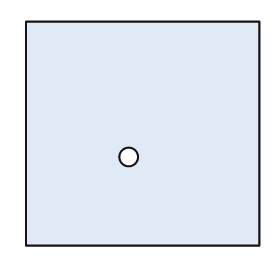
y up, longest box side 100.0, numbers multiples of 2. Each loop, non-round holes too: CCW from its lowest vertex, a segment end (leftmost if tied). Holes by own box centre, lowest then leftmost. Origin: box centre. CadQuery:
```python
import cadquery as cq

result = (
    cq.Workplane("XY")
    .moveTo(-50.0, -48.0)
    .lineTo(50.0, -48.0)
    .lineTo(50.0, 48.0)
    .lineTo(-50.0, 48.0)
    .close()
    .moveTo(-6.0, -10.0)
    .circle(4.0)
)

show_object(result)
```